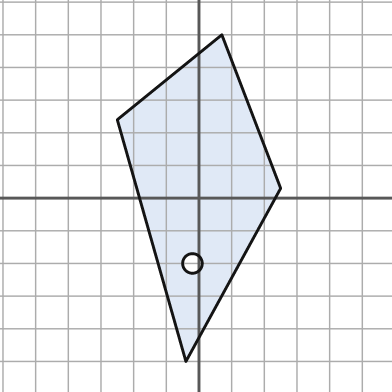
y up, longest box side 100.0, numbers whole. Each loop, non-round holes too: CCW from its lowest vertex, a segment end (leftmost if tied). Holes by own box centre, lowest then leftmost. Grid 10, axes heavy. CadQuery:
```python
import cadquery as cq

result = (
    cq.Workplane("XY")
    .moveTo(-4.0, -50.0)
    .lineTo(25.0, 3.0)
    .lineTo(7.0, 50.0)
    .lineTo(-25.0, 24.0)
    .close()
    .moveTo(-2.0, -20.0)
    .circle(3.0)
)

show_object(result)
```